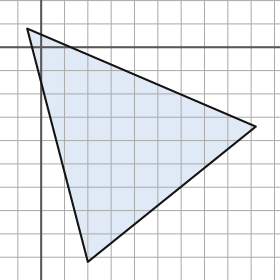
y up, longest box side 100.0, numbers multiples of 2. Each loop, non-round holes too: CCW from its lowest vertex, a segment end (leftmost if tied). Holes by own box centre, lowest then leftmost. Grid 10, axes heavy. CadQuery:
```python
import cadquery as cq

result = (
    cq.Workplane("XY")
    .moveTo(20.0, -92.0)
    .lineTo(92.0, -34.0)
    .lineTo(-6.0, 8.0)
    .close()
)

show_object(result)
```